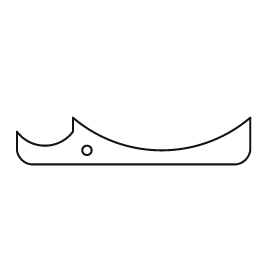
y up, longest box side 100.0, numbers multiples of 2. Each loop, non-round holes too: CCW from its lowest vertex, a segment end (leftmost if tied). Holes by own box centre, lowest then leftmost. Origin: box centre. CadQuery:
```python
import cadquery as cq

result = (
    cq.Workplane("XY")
    .moveTo(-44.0, -10.0)
    .lineTo(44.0, -10.0)
    .threePointArc((48.0, -8.0), (50.0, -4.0))
    .lineTo(50.0, 10.0)
    .threePointArc((12.0, -4.0), (-26.0, 10.0))
    .lineTo(-26.0, 4.0)
    .threePointArc((-38.0, -2.0), (-50.0, 4.0))
    .lineTo(-50.0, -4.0)
    .threePointArc((-48.0, -8.0), (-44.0, -10.0))
    .close()
    .moveTo(-20.0, -4.0)
    .circle(2.0)
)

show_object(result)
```